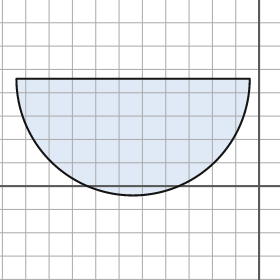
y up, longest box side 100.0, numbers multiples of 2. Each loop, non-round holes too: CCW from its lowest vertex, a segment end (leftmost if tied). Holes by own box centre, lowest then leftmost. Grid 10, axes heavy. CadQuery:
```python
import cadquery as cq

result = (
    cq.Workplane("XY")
    .moveTo(-104.0, 46.0)
    .threePointArc((-54.0, -4.0), (-4.0, 46.0))
    .close()
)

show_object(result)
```